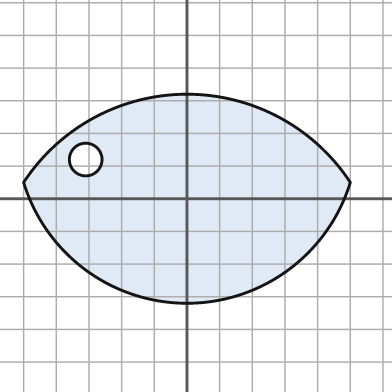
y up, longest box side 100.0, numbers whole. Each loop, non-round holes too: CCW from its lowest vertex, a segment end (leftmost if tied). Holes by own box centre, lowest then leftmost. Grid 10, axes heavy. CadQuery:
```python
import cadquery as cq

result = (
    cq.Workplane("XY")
    .moveTo(-50.0, 5.0)
    .threePointArc((0.0, -32.0), (50.0, 5.0))
    .threePointArc((0.0, 32.0), (-50.0, 5.0))
    .close()
    .moveTo(-31.0, 12.0)
    .circle(5.0)
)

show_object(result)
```